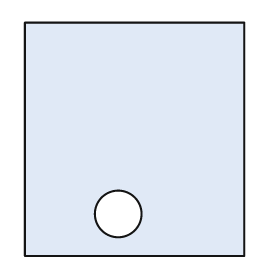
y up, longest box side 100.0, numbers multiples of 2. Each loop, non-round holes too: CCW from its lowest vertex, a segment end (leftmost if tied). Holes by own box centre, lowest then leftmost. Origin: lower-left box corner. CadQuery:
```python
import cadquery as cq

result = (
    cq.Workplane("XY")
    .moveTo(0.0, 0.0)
    .lineTo(94.0, 0.0)
    .lineTo(94.0, 100.0)
    .lineTo(0.0, 100.0)
    .close()
    .moveTo(40.0, 18.0)
    .circle(10.0)
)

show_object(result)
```